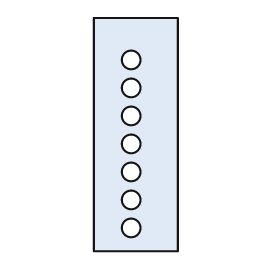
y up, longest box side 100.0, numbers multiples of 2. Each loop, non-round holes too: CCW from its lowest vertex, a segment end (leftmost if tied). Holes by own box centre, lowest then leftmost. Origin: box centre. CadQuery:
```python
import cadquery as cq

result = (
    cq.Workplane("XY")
    .moveTo(-18.0, -50.0)
    .lineTo(18.0, -50.0)
    .lineTo(18.0, 50.0)
    .lineTo(-18.0, 50.0)
    .close()
    .moveTo(-2.0, -40.0)
    .circle(4.0)
    .moveTo(-2.0, -28.0)
    .circle(4.0)
    .moveTo(-2.0, -16.0)
    .circle(4.0)
    .moveTo(-2.0, -4.0)
    .circle(4.0)
    .moveTo(-2.0, 8.0)
    .circle(4.0)
    .moveTo(-2.0, 20.0)
    .circle(4.0)
    .moveTo(-2.0, 32.0)
    .circle(4.0)
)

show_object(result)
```